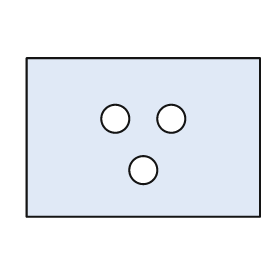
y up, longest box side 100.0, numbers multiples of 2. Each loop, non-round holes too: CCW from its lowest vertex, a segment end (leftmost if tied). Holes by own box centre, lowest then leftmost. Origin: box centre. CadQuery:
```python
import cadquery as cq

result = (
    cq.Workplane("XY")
    .moveTo(-50.0, -34.0)
    .lineTo(50.0, -34.0)
    .lineTo(50.0, 34.0)
    .lineTo(-50.0, 34.0)
    .close()
    .moveTo(0.0, -14.0)
    .circle(6.0)
    .moveTo(-12.0, 8.0)
    .circle(6.0)
    .moveTo(12.0, 8.0)
    .circle(6.0)
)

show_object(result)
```